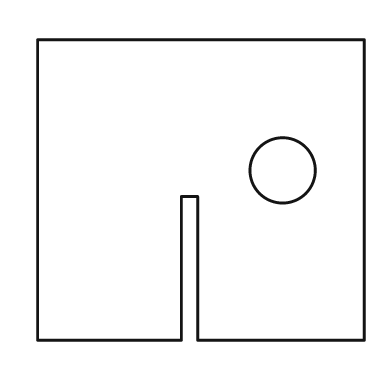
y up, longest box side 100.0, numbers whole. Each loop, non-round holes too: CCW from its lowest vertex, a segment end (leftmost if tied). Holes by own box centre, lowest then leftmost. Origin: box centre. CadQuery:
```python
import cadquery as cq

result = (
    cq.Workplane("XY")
    .moveTo(-50.0, -46.0)
    .lineTo(-6.0, -46.0)
    .lineTo(-6.0, -2.0)
    .lineTo(-1.0, -2.0)
    .lineTo(-1.0, -46.0)
    .lineTo(50.0, -46.0)
    .lineTo(50.0, 46.0)
    .lineTo(-50.0, 46.0)
    .close()
    .moveTo(25.0, 6.0)
    .circle(10.0)
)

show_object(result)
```